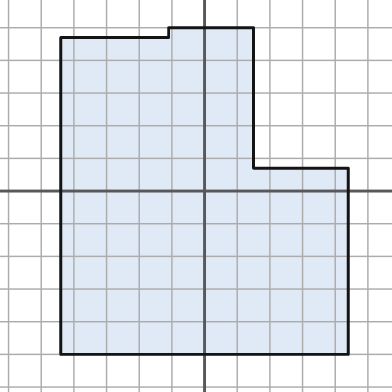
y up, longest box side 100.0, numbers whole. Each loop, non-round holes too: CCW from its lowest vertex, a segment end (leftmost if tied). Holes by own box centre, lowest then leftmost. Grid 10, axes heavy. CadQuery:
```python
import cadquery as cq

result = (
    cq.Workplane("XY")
    .moveTo(-44.0, -50.0)
    .lineTo(44.0, -50.0)
    .lineTo(44.0, 7.0)
    .lineTo(15.0, 7.0)
    .lineTo(15.0, 50.0)
    .lineTo(-11.0, 50.0)
    .lineTo(-11.0, 47.0)
    .lineTo(-44.0, 47.0)
    .close()
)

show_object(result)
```